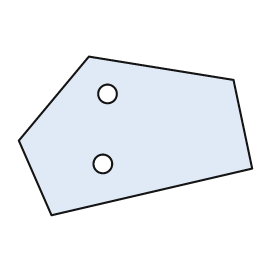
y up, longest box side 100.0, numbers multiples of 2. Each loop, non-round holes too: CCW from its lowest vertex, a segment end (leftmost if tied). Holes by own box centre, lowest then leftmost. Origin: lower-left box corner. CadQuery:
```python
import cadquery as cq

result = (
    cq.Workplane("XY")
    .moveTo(14.0, 0.0)
    .lineTo(100.0, 20.0)
    .lineTo(92.0, 58.0)
    .lineTo(30.0, 68.0)
    .lineTo(0.0, 32.0)
    .close()
    .moveTo(36.0, 22.0)
    .circle(4.0)
    .moveTo(38.0, 52.0)
    .circle(4.0)
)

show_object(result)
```